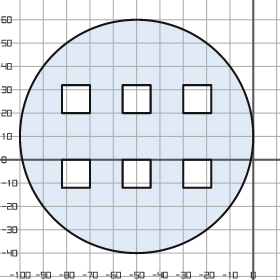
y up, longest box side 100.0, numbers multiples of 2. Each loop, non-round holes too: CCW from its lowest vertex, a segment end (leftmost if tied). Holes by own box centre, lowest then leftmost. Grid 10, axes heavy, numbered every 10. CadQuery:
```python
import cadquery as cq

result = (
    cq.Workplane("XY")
    .moveTo(-50.0, 10.0)
    .circle(50.0)
    .moveTo(-82.0, -12.0)
    .lineTo(-70.0, -12.0)
    .lineTo(-70.0, 0.0)
    .lineTo(-82.0, 0.0)
    .close()
    .moveTo(-56.0, -12.0)
    .lineTo(-44.0, -12.0)
    .lineTo(-44.0, 0.0)
    .lineTo(-56.0, 0.0)
    .close()
    .moveTo(-30.0, -12.0)
    .lineTo(-18.0, -12.0)
    .lineTo(-18.0, 0.0)
    .lineTo(-30.0, 0.0)
    .close()
    .moveTo(-82.0, 20.0)
    .lineTo(-70.0, 20.0)
    .lineTo(-70.0, 32.0)
    .lineTo(-82.0, 32.0)
    .close()
    .moveTo(-56.0, 20.0)
    .lineTo(-44.0, 20.0)
    .lineTo(-44.0, 32.0)
    .lineTo(-56.0, 32.0)
    .close()
    .moveTo(-30.0, 20.0)
    .lineTo(-18.0, 20.0)
    .lineTo(-18.0, 32.0)
    .lineTo(-30.0, 32.0)
    .close()
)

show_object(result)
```